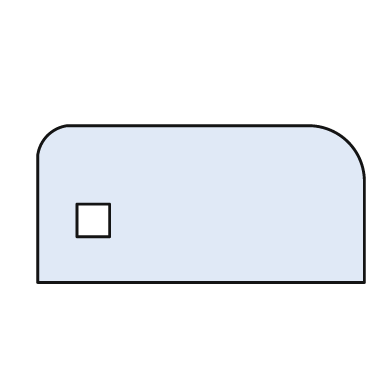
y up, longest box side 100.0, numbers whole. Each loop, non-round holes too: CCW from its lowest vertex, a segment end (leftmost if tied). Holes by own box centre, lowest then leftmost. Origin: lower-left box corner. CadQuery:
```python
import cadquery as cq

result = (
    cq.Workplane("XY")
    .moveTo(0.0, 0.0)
    .lineTo(100.0, 0.0)
    .lineTo(100.0, 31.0)
    .threePointArc((95.0, 43.0), (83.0, 48.0))
    .lineTo(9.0, 48.0)
    .threePointArc((3.0, 45.0), (0.0, 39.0))
    .close()
    .moveTo(12.0, 14.0)
    .lineTo(22.0, 14.0)
    .lineTo(22.0, 24.0)
    .lineTo(12.0, 24.0)
    .close()
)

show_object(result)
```